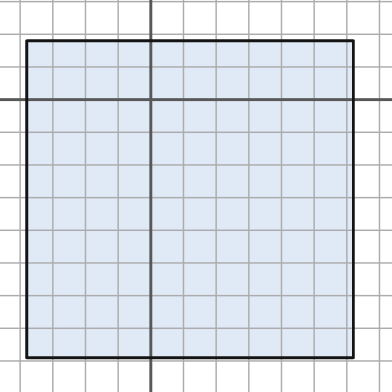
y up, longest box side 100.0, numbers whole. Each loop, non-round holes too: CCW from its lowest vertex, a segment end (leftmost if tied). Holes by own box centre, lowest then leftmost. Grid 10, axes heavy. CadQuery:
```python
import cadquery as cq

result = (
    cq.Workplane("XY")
    .moveTo(-38.0, -79.0)
    .lineTo(62.0, -79.0)
    .lineTo(62.0, 18.0)
    .lineTo(-38.0, 18.0)
    .close()
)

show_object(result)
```